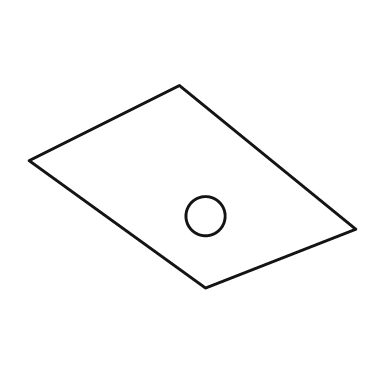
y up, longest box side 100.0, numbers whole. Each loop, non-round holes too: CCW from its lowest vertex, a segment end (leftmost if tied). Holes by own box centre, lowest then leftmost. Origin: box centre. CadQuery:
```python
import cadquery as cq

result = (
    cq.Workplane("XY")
    .moveTo(4.0, -31.0)
    .lineTo(50.0, -13.0)
    .lineTo(-4.0, 31.0)
    .lineTo(-50.0, 8.0)
    .close()
    .moveTo(4.0, -9.0)
    .circle(6.0)
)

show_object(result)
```